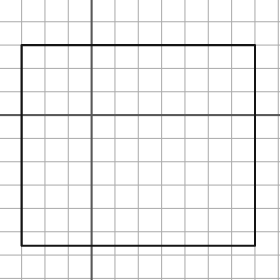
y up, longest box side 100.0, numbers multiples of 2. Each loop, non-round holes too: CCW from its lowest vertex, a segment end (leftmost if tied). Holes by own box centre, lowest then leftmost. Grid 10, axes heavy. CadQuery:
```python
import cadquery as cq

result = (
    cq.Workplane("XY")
    .moveTo(-30.0, -56.0)
    .lineTo(70.0, -56.0)
    .lineTo(70.0, 30.0)
    .lineTo(-30.0, 30.0)
    .close()
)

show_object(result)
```